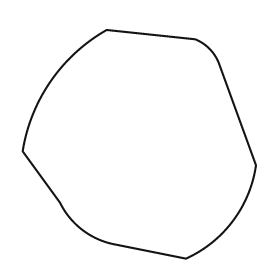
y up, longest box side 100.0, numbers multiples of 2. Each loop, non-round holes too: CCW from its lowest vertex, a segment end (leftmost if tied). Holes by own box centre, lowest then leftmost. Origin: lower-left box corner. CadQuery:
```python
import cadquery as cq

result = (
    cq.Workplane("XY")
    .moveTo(70.0, 0.0)
    .threePointArc((90.0, 16.0), (100.0, 40.0))
    .lineTo(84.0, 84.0)
    .threePointArc((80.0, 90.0), (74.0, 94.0))
    .lineTo(36.0, 98.0)
    .threePointArc((12.0, 76.0), (0.0, 46.0))
    .lineTo(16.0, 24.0)
    .threePointArc((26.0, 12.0), (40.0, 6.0))
    .close()
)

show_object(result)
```